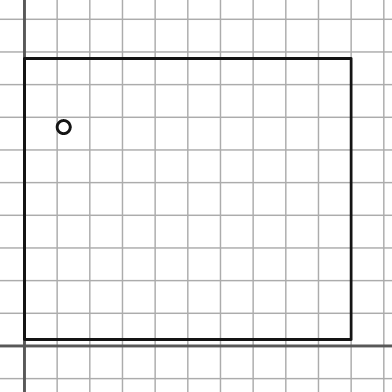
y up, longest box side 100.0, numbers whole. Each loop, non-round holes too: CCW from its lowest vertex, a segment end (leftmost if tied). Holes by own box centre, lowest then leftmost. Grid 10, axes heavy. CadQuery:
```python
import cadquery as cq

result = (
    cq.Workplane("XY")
    .moveTo(0.0, 2.0)
    .lineTo(100.0, 2.0)
    .lineTo(100.0, 88.0)
    .lineTo(0.0, 88.0)
    .close()
    .moveTo(12.0, 67.0)
    .circle(2.0)
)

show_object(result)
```